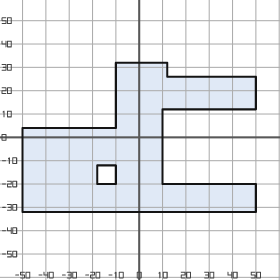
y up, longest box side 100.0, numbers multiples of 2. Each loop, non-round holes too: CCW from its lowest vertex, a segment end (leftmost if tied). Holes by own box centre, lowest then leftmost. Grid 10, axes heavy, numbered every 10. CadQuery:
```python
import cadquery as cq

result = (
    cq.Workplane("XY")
    .moveTo(-50.0, -32.0)
    .lineTo(50.0, -32.0)
    .lineTo(50.0, -20.0)
    .lineTo(10.0, -20.0)
    .lineTo(10.0, 12.0)
    .lineTo(50.0, 12.0)
    .lineTo(50.0, 26.0)
    .lineTo(12.0, 26.0)
    .lineTo(12.0, 32.0)
    .lineTo(-10.0, 32.0)
    .lineTo(-10.0, 4.0)
    .lineTo(-50.0, 4.0)
    .close()
    .moveTo(-18.0, -20.0)
    .lineTo(-10.0, -20.0)
    .lineTo(-10.0, -12.0)
    .lineTo(-18.0, -12.0)
    .close()
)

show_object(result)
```